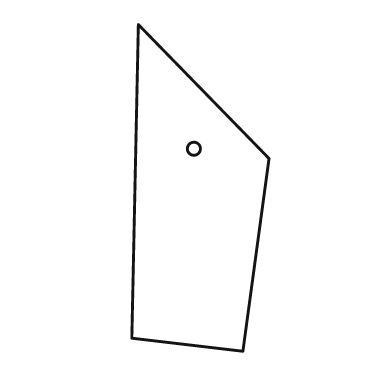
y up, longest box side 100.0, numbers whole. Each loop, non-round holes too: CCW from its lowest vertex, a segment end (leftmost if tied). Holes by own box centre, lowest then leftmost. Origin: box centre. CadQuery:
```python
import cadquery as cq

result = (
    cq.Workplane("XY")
    .moveTo(13.0, -50.0)
    .lineTo(21.0, 9.0)
    .lineTo(-19.0, 50.0)
    .lineTo(-21.0, -46.0)
    .close()
    .moveTo(-2.0, 12.0)
    .circle(2.0)
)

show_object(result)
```